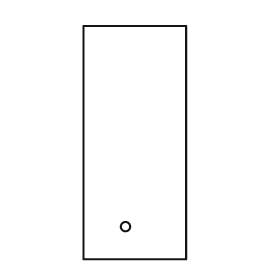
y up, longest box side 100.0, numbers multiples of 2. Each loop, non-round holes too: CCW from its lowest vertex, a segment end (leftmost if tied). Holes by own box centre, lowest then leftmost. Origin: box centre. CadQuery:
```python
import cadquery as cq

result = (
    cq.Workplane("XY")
    .moveTo(-22.0, -50.0)
    .lineTo(22.0, -50.0)
    .lineTo(22.0, 50.0)
    .lineTo(-22.0, 50.0)
    .close()
    .moveTo(-4.0, -36.0)
    .circle(2.0)
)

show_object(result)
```